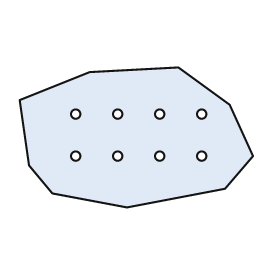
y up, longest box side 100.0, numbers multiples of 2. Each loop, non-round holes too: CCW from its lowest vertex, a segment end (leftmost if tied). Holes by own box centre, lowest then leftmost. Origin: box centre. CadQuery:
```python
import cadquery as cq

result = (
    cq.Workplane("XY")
    .moveTo(-4.0, -30.0)
    .lineTo(38.0, -22.0)
    .lineTo(50.0, -8.0)
    .lineTo(40.0, 14.0)
    .lineTo(18.0, 30.0)
    .lineTo(-20.0, 28.0)
    .lineTo(-50.0, 16.0)
    .lineTo(-46.0, -12.0)
    .lineTo(-36.0, -24.0)
    .close()
    .moveTo(-26.0, -8.0)
    .circle(2.0)
    .moveTo(-8.0, -8.0)
    .circle(2.0)
    .moveTo(10.0, -8.0)
    .circle(2.0)
    .moveTo(28.0, -8.0)
    .circle(2.0)
    .moveTo(-26.0, 10.0)
    .circle(2.0)
    .moveTo(-8.0, 10.0)
    .circle(2.0)
    .moveTo(10.0, 10.0)
    .circle(2.0)
    .moveTo(28.0, 10.0)
    .circle(2.0)
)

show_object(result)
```